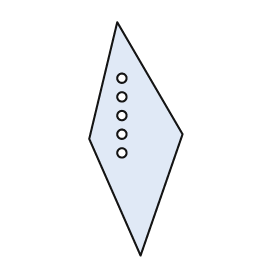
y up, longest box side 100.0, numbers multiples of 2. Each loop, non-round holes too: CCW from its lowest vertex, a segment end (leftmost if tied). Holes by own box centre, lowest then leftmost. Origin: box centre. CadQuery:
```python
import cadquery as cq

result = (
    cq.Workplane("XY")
    .moveTo(2.0, -50.0)
    .lineTo(20.0, 2.0)
    .lineTo(-8.0, 50.0)
    .lineTo(-20.0, 0.0)
    .close()
    .moveTo(-6.0, -6.0)
    .circle(2.0)
    .moveTo(-6.0, 2.0)
    .circle(2.0)
    .moveTo(-6.0, 10.0)
    .circle(2.0)
    .moveTo(-6.0, 18.0)
    .circle(2.0)
    .moveTo(-6.0, 26.0)
    .circle(2.0)
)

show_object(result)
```